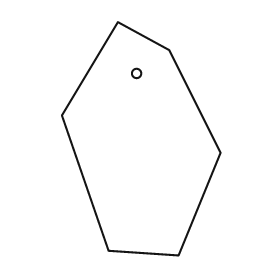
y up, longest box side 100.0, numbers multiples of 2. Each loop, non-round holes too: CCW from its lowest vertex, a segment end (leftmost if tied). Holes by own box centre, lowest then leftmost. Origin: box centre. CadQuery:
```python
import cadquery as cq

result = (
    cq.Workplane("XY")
    .moveTo(16.0, -50.0)
    .lineTo(34.0, -6.0)
    .lineTo(12.0, 38.0)
    .lineTo(-10.0, 50.0)
    .lineTo(-34.0, 10.0)
    .lineTo(-14.0, -48.0)
    .close()
    .moveTo(-2.0, 28.0)
    .circle(2.0)
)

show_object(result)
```